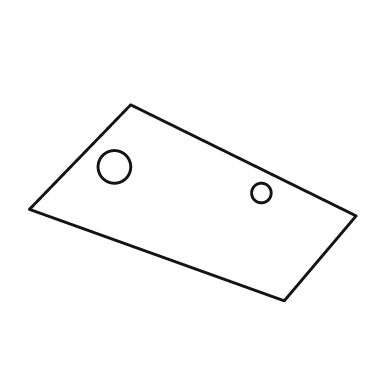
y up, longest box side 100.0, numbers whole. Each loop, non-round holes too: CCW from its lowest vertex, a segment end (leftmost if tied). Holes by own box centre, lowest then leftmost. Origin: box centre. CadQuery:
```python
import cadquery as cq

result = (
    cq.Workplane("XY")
    .moveTo(28.0, -30.0)
    .lineTo(50.0, -4.0)
    .lineTo(-19.0, 30.0)
    .lineTo(-50.0, -2.0)
    .close()
    .moveTo(21.0, 3.0)
    .circle(3.0)
    .moveTo(-24.0, 11.0)
    .circle(5.0)
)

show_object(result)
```